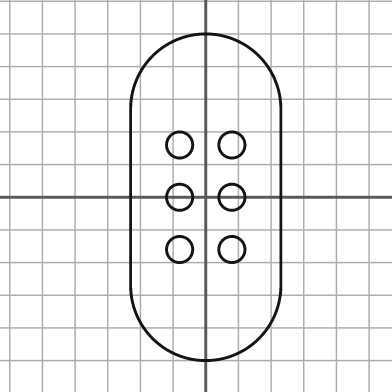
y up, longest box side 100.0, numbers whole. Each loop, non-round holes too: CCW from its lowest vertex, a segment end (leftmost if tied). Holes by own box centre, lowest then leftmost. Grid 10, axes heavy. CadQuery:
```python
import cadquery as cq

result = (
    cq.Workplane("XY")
    .moveTo(-23.0, -27.0)
    .threePointArc((0.0, -50.0), (23.0, -27.0))
    .lineTo(23.0, 27.0)
    .threePointArc((0.0, 50.0), (-23.0, 27.0))
    .close()
    .moveTo(-8.0, -16.0)
    .circle(4.0)
    .moveTo(8.0, -16.0)
    .circle(4.0)
    .moveTo(-8.0, 0.0)
    .circle(4.0)
    .moveTo(8.0, 0.0)
    .circle(4.0)
    .moveTo(-8.0, 16.0)
    .circle(4.0)
    .moveTo(8.0, 16.0)
    .circle(4.0)
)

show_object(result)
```